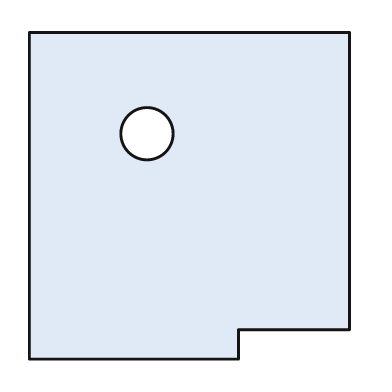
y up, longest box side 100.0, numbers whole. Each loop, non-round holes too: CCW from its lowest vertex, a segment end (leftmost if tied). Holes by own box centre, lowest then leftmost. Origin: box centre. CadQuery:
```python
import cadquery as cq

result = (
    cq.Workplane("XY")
    .moveTo(-49.0, -50.0)
    .lineTo(15.0, -50.0)
    .lineTo(15.0, -41.0)
    .lineTo(49.0, -41.0)
    .lineTo(49.0, 50.0)
    .lineTo(-49.0, 50.0)
    .close()
    .moveTo(-13.0, 19.0)
    .circle(8.0)
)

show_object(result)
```